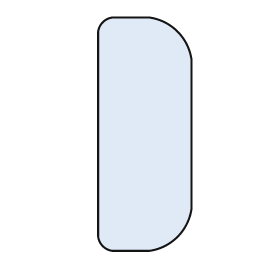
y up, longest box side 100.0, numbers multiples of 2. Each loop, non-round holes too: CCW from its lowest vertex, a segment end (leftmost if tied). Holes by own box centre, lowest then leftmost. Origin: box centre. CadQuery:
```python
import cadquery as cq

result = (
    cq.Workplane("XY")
    .moveTo(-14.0, -50.0)
    .lineTo(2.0, -50.0)
    .threePointArc((14.0, -44.0), (20.0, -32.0))
    .lineTo(20.0, 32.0)
    .threePointArc((14.0, 44.0), (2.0, 50.0))
    .lineTo(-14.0, 50.0)
    .threePointArc((-18.0, 48.0), (-20.0, 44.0))
    .lineTo(-20.0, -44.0)
    .threePointArc((-18.0, -48.0), (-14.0, -50.0))
    .close()
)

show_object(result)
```